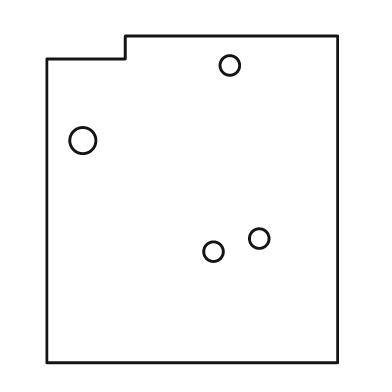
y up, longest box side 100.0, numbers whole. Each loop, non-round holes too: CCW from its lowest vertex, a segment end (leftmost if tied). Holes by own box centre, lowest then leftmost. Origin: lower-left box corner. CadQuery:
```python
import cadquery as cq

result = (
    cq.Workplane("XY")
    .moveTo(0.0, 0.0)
    .lineTo(89.0, 0.0)
    .lineTo(89.0, 100.0)
    .lineTo(24.0, 100.0)
    .lineTo(24.0, 93.0)
    .lineTo(0.0, 93.0)
    .close()
    .moveTo(51.0, 34.0)
    .circle(3.0)
    .moveTo(65.0, 38.0)
    .circle(3.0)
    .moveTo(11.0, 68.0)
    .circle(4.0)
    .moveTo(56.0, 91.0)
    .circle(3.0)
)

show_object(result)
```